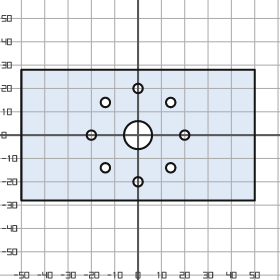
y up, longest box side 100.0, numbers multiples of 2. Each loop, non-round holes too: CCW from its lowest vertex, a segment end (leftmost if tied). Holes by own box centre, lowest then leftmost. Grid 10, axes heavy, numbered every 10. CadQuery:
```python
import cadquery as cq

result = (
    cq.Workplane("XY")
    .moveTo(-50.0, -28.0)
    .lineTo(50.0, -28.0)
    .lineTo(50.0, 28.0)
    .lineTo(-50.0, 28.0)
    .close()
    .moveTo(0.0, -20.0)
    .circle(2.0)
    .moveTo(-14.0, -14.0)
    .circle(2.0)
    .moveTo(14.0, -14.0)
    .circle(2.0)
    .moveTo(-20.0, 0.0)
    .circle(2.0)
    .moveTo(0.0, 0.0)
    .circle(6.0)
    .moveTo(20.0, 0.0)
    .circle(2.0)
    .moveTo(-14.0, 14.0)
    .circle(2.0)
    .moveTo(14.0, 14.0)
    .circle(2.0)
    .moveTo(0.0, 20.0)
    .circle(2.0)
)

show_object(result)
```